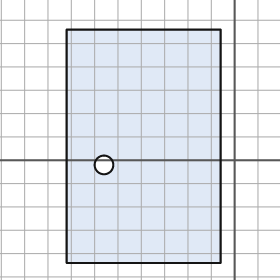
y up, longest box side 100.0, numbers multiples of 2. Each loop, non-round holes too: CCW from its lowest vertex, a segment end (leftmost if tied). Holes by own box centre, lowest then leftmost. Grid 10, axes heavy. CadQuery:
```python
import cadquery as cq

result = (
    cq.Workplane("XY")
    .moveTo(-72.0, -44.0)
    .lineTo(-6.0, -44.0)
    .lineTo(-6.0, 56.0)
    .lineTo(-72.0, 56.0)
    .close()
    .moveTo(-56.0, -2.0)
    .circle(4.0)
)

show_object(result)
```